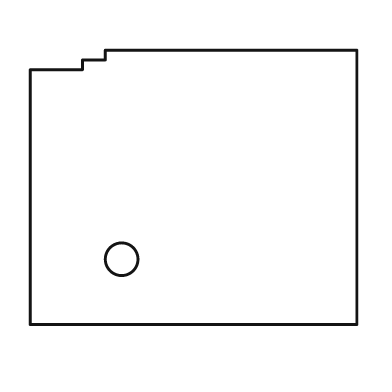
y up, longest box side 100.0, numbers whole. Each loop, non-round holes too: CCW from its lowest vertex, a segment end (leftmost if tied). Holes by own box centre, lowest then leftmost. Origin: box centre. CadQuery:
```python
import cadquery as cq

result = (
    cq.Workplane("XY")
    .moveTo(-50.0, -42.0)
    .lineTo(50.0, -42.0)
    .lineTo(50.0, 42.0)
    .lineTo(-27.0, 42.0)
    .lineTo(-27.0, 39.0)
    .lineTo(-34.0, 39.0)
    .lineTo(-34.0, 36.0)
    .lineTo(-50.0, 36.0)
    .close()
    .moveTo(-22.0, -22.0)
    .circle(5.0)
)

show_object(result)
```